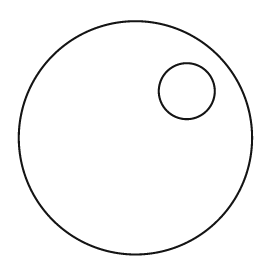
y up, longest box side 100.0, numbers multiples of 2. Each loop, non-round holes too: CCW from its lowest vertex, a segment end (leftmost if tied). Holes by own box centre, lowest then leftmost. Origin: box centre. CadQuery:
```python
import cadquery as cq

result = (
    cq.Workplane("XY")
    .moveTo(0.0, 0.0)
    .circle(50.0)
    .moveTo(22.0, 20.0)
    .circle(12.0)
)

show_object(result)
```